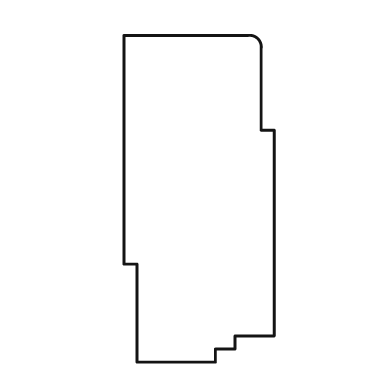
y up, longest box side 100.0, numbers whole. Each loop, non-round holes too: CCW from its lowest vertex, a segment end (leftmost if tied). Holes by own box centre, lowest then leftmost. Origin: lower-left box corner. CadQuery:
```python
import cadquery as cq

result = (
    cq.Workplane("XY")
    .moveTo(4.0, 0.0)
    .lineTo(28.0, 0.0)
    .lineTo(28.0, 4.0)
    .lineTo(34.0, 4.0)
    .lineTo(34.0, 8.0)
    .lineTo(46.0, 8.0)
    .lineTo(46.0, 71.0)
    .lineTo(42.0, 71.0)
    .lineTo(42.0, 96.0)
    .threePointArc((41.0, 99.0), (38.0, 100.0))
    .lineTo(0.0, 100.0)
    .lineTo(0.0, 30.0)
    .lineTo(4.0, 30.0)
    .close()
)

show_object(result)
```